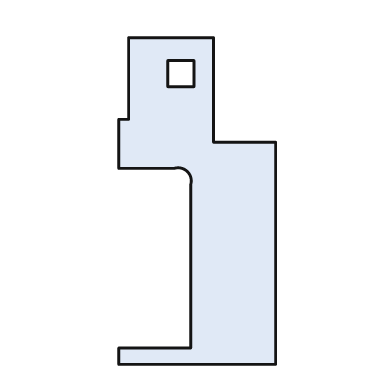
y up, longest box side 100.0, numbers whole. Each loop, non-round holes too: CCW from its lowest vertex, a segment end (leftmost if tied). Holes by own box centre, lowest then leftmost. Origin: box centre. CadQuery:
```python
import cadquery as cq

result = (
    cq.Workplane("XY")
    .moveTo(-24.0, -50.0)
    .lineTo(24.0, -50.0)
    .lineTo(24.0, 18.0)
    .lineTo(5.0, 18.0)
    .lineTo(5.0, 50.0)
    .lineTo(-21.0, 50.0)
    .lineTo(-21.0, 25.0)
    .lineTo(-24.0, 25.0)
    .lineTo(-24.0, 10.0)
    .lineTo(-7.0, 10.0)
    .threePointArc((-3.0, 9.0), (-2.0, 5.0))
    .lineTo(-2.0, -45.0)
    .lineTo(-24.0, -45.0)
    .close()
    .moveTo(-9.0, 35.0)
    .lineTo(-1.0, 35.0)
    .lineTo(-1.0, 43.0)
    .lineTo(-9.0, 43.0)
    .close()
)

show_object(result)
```